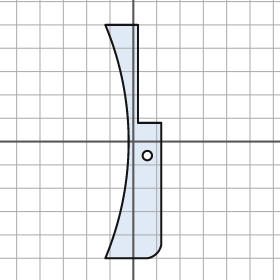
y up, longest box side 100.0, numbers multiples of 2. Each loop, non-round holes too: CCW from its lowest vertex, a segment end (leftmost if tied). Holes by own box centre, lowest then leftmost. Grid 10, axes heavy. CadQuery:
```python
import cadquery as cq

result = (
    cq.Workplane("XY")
    .moveTo(-12.0, -50.0)
    .lineTo(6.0, -50.0)
    .threePointArc((10.0, -48.0), (12.0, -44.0))
    .lineTo(12.0, 8.0)
    .lineTo(2.0, 8.0)
    .lineTo(2.0, 50.0)
    .lineTo(-12.0, 50.0)
    .threePointArc((-2.0, 0.0), (-12.0, -50.0))
    .close()
    .moveTo(6.0, -6.0)
    .circle(2.0)
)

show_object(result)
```